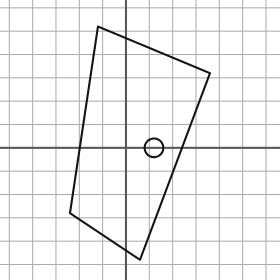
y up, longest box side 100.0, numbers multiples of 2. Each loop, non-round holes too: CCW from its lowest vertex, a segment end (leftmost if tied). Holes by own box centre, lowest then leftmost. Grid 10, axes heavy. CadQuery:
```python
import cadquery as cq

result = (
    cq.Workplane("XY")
    .moveTo(6.0, -48.0)
    .lineTo(36.0, 32.0)
    .lineTo(-12.0, 52.0)
    .lineTo(-24.0, -28.0)
    .close()
    .moveTo(12.0, 0.0)
    .circle(4.0)
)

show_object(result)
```